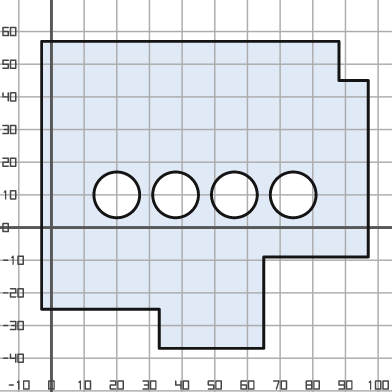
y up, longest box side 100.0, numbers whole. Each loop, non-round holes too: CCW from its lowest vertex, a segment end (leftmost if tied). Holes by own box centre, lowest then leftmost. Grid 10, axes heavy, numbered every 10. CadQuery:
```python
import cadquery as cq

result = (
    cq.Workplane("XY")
    .moveTo(33.0, -37.0)
    .lineTo(65.0, -37.0)
    .lineTo(65.0, -9.0)
    .lineTo(97.0, -9.0)
    .lineTo(97.0, 45.0)
    .lineTo(88.0, 45.0)
    .lineTo(88.0, 57.0)
    .lineTo(-3.0, 57.0)
    .lineTo(-3.0, -25.0)
    .lineTo(33.0, -25.0)
    .close()
    .moveTo(20.0, 10.0)
    .circle(7.0)
    .moveTo(38.0, 10.0)
    .circle(7.0)
    .moveTo(56.0, 10.0)
    .circle(7.0)
    .moveTo(74.0, 10.0)
    .circle(7.0)
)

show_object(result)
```